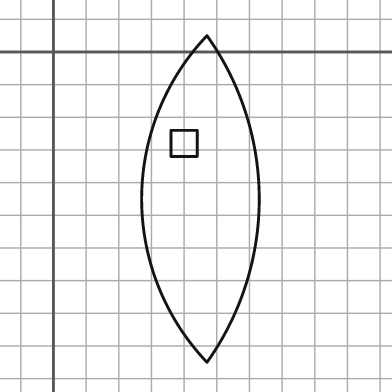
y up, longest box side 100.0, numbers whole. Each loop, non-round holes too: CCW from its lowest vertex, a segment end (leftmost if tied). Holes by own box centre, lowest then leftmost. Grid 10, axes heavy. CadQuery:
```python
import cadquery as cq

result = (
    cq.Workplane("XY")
    .moveTo(47.0, -95.0)
    .threePointArc((63.0, -45.0), (47.0, 5.0))
    .threePointArc((27.0, -45.0), (47.0, -95.0))
    .close()
    .moveTo(36.0, -32.0)
    .lineTo(44.0, -32.0)
    .lineTo(44.0, -24.0)
    .lineTo(36.0, -24.0)
    .close()
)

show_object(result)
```